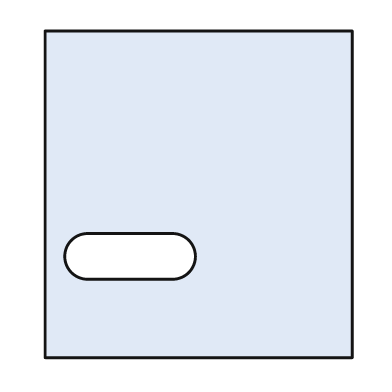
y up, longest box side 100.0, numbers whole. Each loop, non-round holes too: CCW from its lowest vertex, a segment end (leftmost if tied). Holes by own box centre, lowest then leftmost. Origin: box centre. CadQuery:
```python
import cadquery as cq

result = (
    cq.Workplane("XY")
    .moveTo(-47.0, -50.0)
    .lineTo(47.0, -50.0)
    .lineTo(47.0, 50.0)
    .lineTo(-47.0, 50.0)
    .close()
    .moveTo(-34.0, -26.0)
    .lineTo(-8.0, -26.0)
    .threePointArc((-1.0, -19.0), (-8.0, -12.0))
    .lineTo(-34.0, -12.0)
    .threePointArc((-41.0, -19.0), (-34.0, -26.0))
    .close()
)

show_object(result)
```